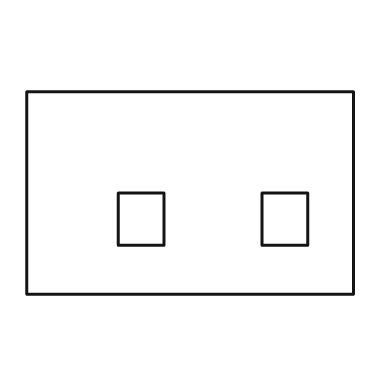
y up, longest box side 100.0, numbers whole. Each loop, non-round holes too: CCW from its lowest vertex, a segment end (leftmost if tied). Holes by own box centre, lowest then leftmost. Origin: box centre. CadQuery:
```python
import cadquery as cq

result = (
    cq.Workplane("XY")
    .moveTo(-50.0, -31.0)
    .lineTo(50.0, -31.0)
    .lineTo(50.0, 31.0)
    .lineTo(-50.0, 31.0)
    .close()
    .moveTo(-22.0, -16.0)
    .lineTo(-8.0, -16.0)
    .lineTo(-8.0, 0.0)
    .lineTo(-22.0, 0.0)
    .close()
    .moveTo(22.0, -16.0)
    .lineTo(36.0, -16.0)
    .lineTo(36.0, 0.0)
    .lineTo(22.0, 0.0)
    .close()
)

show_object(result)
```